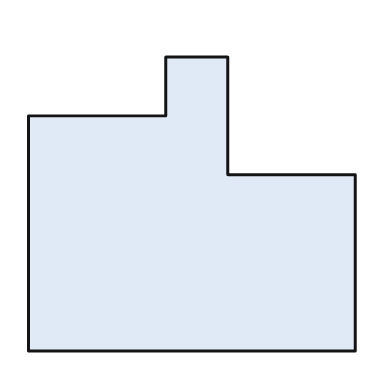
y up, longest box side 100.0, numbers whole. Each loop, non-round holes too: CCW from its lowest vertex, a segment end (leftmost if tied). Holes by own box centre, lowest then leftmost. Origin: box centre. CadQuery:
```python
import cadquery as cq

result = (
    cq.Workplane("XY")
    .moveTo(-50.0, -45.0)
    .lineTo(50.0, -45.0)
    .lineTo(50.0, 9.0)
    .lineTo(11.0, 9.0)
    .lineTo(11.0, 45.0)
    .lineTo(-8.0, 45.0)
    .lineTo(-8.0, 27.0)
    .lineTo(-50.0, 27.0)
    .close()
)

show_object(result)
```